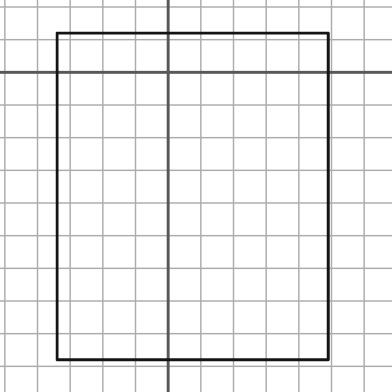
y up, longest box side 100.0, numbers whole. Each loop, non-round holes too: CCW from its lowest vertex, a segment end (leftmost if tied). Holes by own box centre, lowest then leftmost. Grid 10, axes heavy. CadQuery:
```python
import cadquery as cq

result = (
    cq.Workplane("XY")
    .moveTo(-34.0, -88.0)
    .lineTo(49.0, -88.0)
    .lineTo(49.0, 12.0)
    .lineTo(-34.0, 12.0)
    .close()
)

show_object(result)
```